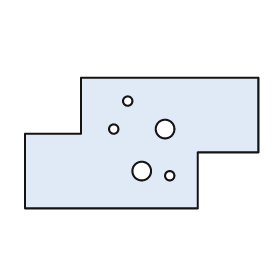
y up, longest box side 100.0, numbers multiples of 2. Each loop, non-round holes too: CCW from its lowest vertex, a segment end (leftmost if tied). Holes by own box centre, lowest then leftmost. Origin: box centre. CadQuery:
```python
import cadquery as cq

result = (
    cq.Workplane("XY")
    .moveTo(-50.0, -28.0)
    .lineTo(24.0, -28.0)
    .lineTo(24.0, -4.0)
    .lineTo(50.0, -4.0)
    .lineTo(50.0, 28.0)
    .lineTo(-26.0, 28.0)
    .lineTo(-26.0, 4.0)
    .lineTo(-50.0, 4.0)
    .close()
    .moveTo(12.0, -14.0)
    .circle(2.0)
    .moveTo(0.0, -12.0)
    .circle(4.0)
    .moveTo(-12.0, 6.0)
    .circle(2.0)
    .moveTo(10.0, 6.0)
    .circle(4.0)
    .moveTo(-6.0, 18.0)
    .circle(2.0)
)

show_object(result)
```